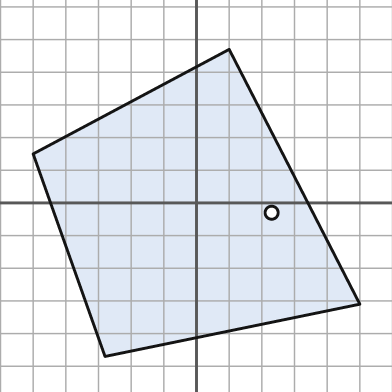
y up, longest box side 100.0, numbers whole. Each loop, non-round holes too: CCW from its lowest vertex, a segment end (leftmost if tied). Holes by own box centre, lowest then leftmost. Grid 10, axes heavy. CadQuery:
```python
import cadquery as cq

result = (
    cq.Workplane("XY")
    .moveTo(-28.0, -47.0)
    .lineTo(50.0, -31.0)
    .lineTo(10.0, 47.0)
    .lineTo(-50.0, 15.0)
    .close()
    .moveTo(23.0, -3.0)
    .circle(2.0)
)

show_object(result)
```